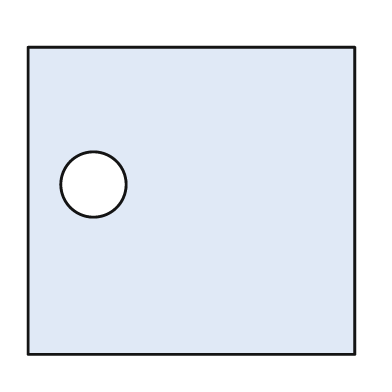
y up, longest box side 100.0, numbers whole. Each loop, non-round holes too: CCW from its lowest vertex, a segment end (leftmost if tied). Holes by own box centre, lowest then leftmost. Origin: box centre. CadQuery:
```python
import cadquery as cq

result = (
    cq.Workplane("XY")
    .moveTo(-50.0, -47.0)
    .lineTo(50.0, -47.0)
    .lineTo(50.0, 47.0)
    .lineTo(-50.0, 47.0)
    .close()
    .moveTo(-30.0, 5.0)
    .circle(10.0)
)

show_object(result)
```